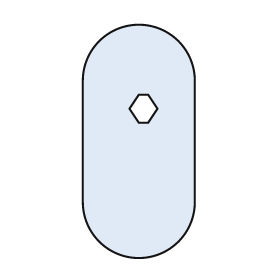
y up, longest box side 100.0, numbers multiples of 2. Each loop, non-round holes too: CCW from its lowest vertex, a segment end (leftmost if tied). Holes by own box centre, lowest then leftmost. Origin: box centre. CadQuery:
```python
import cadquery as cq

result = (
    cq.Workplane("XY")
    .moveTo(-24.0, -26.0)
    .threePointArc((0.0, -50.0), (24.0, -26.0))
    .lineTo(24.0, 26.0)
    .threePointArc((0.0, 50.0), (-24.0, 26.0))
    .close()
    .moveTo(0.0, 8.0)
    .lineTo(4.0, 8.0)
    .lineTo(8.0, 14.0)
    .lineTo(4.0, 20.0)
    .lineTo(0.0, 20.0)
    .lineTo(-4.0, 14.0)
    .close()
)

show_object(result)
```